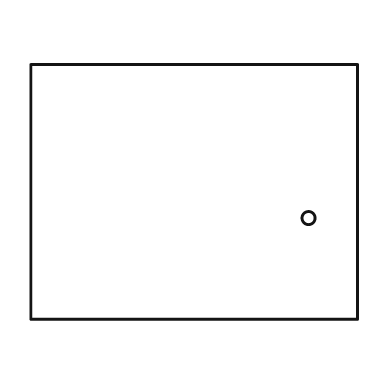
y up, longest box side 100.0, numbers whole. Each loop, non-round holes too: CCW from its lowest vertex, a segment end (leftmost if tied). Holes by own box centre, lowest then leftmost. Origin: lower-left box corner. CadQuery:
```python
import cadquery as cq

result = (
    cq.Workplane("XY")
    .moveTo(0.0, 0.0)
    .lineTo(100.0, 0.0)
    .lineTo(100.0, 78.0)
    .lineTo(0.0, 78.0)
    .close()
    .moveTo(85.0, 31.0)
    .circle(2.0)
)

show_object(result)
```